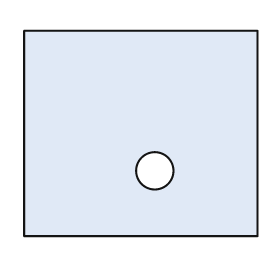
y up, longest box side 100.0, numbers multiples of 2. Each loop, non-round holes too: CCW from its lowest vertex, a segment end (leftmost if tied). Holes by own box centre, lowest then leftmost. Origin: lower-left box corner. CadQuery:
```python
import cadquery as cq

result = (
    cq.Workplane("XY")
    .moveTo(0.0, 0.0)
    .lineTo(100.0, 0.0)
    .lineTo(100.0, 88.0)
    .lineTo(0.0, 88.0)
    .close()
    .moveTo(56.0, 28.0)
    .circle(8.0)
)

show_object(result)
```